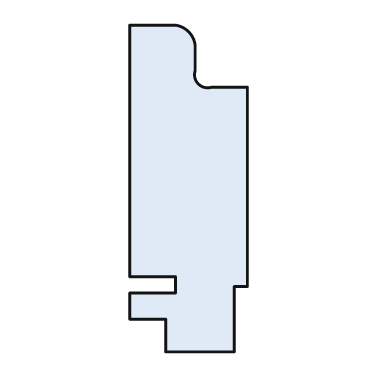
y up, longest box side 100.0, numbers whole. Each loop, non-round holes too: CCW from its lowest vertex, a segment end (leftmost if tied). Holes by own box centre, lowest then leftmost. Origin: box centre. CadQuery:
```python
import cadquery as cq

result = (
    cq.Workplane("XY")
    .moveTo(-7.0, -50.0)
    .lineTo(14.0, -50.0)
    .lineTo(14.0, -30.0)
    .lineTo(18.0, -30.0)
    .lineTo(18.0, 31.0)
    .lineTo(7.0, 31.0)
    .threePointArc((3.0, 32.0), (2.0, 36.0))
    .lineTo(2.0, 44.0)
    .threePointArc((0.0, 48.0), (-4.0, 50.0))
    .lineTo(-18.0, 50.0)
    .lineTo(-18.0, -27.0)
    .lineTo(-4.0, -27.0)
    .lineTo(-4.0, -32.0)
    .lineTo(-18.0, -32.0)
    .lineTo(-18.0, -40.0)
    .lineTo(-7.0, -40.0)
    .close()
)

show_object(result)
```